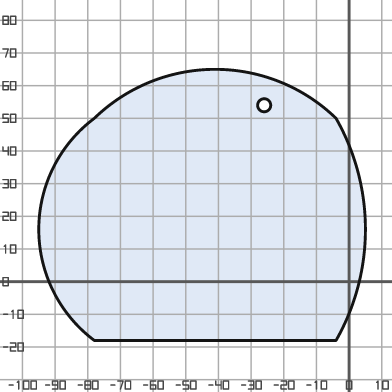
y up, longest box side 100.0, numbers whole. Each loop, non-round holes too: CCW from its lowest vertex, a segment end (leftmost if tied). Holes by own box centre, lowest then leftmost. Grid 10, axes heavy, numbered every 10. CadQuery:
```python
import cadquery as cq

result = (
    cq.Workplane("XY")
    .moveTo(-78.0, -18.0)
    .lineTo(-4.0, -18.0)
    .threePointArc((5.0, 16.0), (-4.0, 50.0))
    .threePointArc((-41.0, 65.0), (-78.0, 50.0))
    .threePointArc((-95.0, 16.0), (-78.0, -18.0))
    .close()
    .moveTo(-26.0, 54.0)
    .circle(2.0)
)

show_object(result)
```